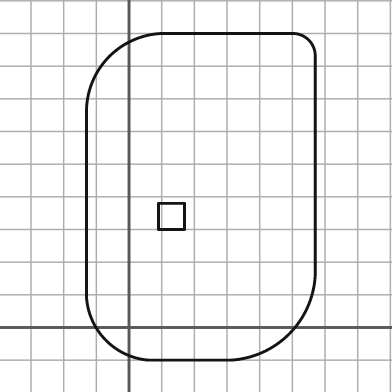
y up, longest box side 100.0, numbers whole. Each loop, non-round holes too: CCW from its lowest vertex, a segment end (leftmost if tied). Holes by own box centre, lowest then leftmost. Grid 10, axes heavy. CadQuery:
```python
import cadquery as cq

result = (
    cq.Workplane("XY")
    .moveTo(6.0, -10.0)
    .lineTo(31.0, -10.0)
    .threePointArc((49.0, -2.0), (57.0, 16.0))
    .lineTo(57.0, 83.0)
    .threePointArc((55.0, 88.0), (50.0, 90.0))
    .lineTo(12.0, 90.0)
    .threePointArc((-6.0, 83.0), (-13.0, 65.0))
    .lineTo(-13.0, 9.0)
    .threePointArc((-7.0, -4.0), (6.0, -10.0))
    .close()
    .moveTo(9.0, 30.0)
    .lineTo(17.0, 30.0)
    .lineTo(17.0, 38.0)
    .lineTo(9.0, 38.0)
    .close()
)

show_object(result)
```